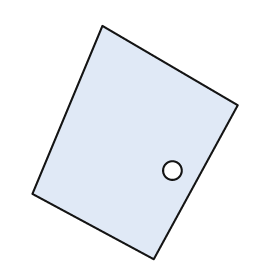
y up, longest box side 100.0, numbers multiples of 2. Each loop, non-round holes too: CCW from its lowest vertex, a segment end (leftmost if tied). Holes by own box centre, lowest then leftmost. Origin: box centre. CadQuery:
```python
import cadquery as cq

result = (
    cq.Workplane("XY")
    .moveTo(8.0, -50.0)
    .lineTo(44.0, 16.0)
    .lineTo(-14.0, 50.0)
    .lineTo(-44.0, -22.0)
    .close()
    .moveTo(16.0, -12.0)
    .circle(4.0)
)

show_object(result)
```